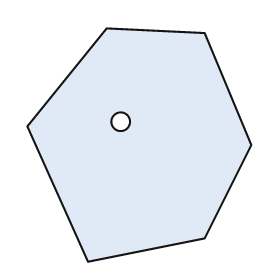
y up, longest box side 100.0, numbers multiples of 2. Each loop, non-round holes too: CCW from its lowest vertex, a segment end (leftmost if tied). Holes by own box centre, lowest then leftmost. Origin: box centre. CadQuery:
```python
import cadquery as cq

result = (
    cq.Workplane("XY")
    .moveTo(-22.0, -50.0)
    .lineTo(28.0, -40.0)
    .lineTo(48.0, 0.0)
    .lineTo(28.0, 48.0)
    .lineTo(-14.0, 50.0)
    .lineTo(-48.0, 8.0)
    .close()
    .moveTo(-8.0, 10.0)
    .circle(4.0)
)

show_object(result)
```